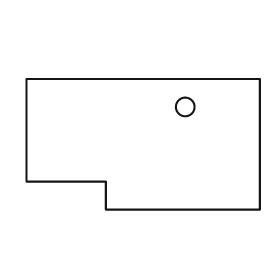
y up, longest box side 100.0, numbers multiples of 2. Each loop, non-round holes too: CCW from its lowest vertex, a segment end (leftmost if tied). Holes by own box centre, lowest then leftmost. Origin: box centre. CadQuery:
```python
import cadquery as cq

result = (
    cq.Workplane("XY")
    .moveTo(-16.0, -28.0)
    .lineTo(50.0, -28.0)
    .lineTo(50.0, 28.0)
    .lineTo(-50.0, 28.0)
    .lineTo(-50.0, -16.0)
    .lineTo(-16.0, -16.0)
    .close()
    .moveTo(18.0, 16.0)
    .circle(4.0)
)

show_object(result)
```